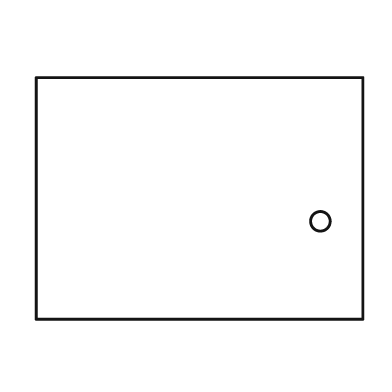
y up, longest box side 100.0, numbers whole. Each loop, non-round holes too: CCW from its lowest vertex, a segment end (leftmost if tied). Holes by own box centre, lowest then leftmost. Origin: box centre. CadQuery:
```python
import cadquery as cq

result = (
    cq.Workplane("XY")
    .moveTo(-50.0, -37.0)
    .lineTo(50.0, -37.0)
    .lineTo(50.0, 37.0)
    .lineTo(-50.0, 37.0)
    .close()
    .moveTo(37.0, -7.0)
    .circle(3.0)
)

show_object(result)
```